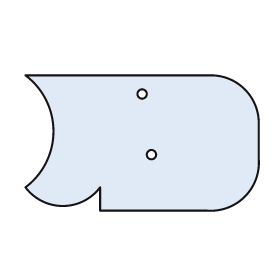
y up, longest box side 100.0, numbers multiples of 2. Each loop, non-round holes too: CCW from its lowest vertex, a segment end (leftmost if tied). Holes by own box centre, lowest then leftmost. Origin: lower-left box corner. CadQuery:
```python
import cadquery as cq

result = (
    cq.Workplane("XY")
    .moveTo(32.0, 0.0)
    .lineTo(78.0, 0.0)
    .threePointArc((94.0, 6.0), (100.0, 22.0))
    .lineTo(100.0, 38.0)
    .threePointArc((94.0, 52.0), (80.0, 58.0))
    .lineTo(0.0, 58.0)
    .threePointArc((12.0, 34.0), (0.0, 10.0))
    .threePointArc((16.0, 2.0), (32.0, 10.0))
    .close()
    .moveTo(54.0, 24.0)
    .circle(2.0)
    .moveTo(50.0, 50.0)
    .circle(2.0)
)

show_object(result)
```